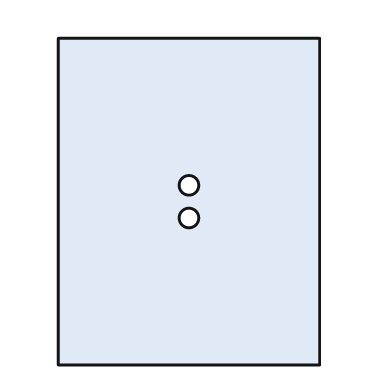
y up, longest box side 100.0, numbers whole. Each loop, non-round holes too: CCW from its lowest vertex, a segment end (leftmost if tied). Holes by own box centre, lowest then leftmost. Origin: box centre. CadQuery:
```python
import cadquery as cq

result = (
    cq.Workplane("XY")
    .moveTo(-40.0, -50.0)
    .lineTo(40.0, -50.0)
    .lineTo(40.0, 50.0)
    .lineTo(-40.0, 50.0)
    .close()
    .moveTo(0.0, -5.0)
    .circle(3.0)
    .moveTo(0.0, 5.0)
    .circle(3.0)
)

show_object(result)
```